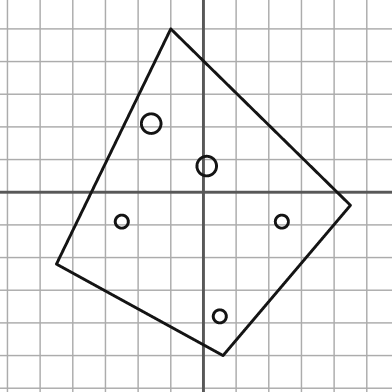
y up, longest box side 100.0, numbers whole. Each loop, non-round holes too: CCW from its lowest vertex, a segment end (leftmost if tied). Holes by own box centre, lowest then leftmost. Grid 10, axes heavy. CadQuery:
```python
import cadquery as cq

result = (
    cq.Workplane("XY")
    .moveTo(6.0, -50.0)
    .lineTo(45.0, -4.0)
    .lineTo(-10.0, 50.0)
    .lineTo(-45.0, -22.0)
    .close()
    .moveTo(5.0, -38.0)
    .circle(2.0)
    .moveTo(-25.0, -9.0)
    .circle(2.0)
    .moveTo(24.0, -9.0)
    .circle(2.0)
    .moveTo(1.0, 8.0)
    .circle(3.0)
    .moveTo(-16.0, 21.0)
    .circle(3.0)
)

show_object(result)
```